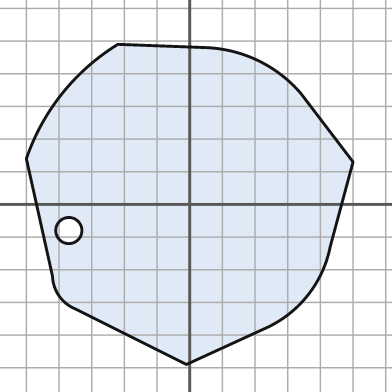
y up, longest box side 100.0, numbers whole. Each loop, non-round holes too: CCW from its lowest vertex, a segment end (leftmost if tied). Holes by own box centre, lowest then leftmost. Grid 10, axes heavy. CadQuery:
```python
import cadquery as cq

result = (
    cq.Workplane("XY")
    .moveTo(-1.0, -49.0)
    .lineTo(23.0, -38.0)
    .threePointArc((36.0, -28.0), (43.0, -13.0))
    .lineTo(50.0, 13.0)
    .lineTo(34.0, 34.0)
    .threePointArc((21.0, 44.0), (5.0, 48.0))
    .lineTo(-22.0, 49.0)
    .threePointArc((-39.0, 34.0), (-50.0, 14.0))
    .lineTo(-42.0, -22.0)
    .threePointArc((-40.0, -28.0), (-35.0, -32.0))
    .close()
    .moveTo(-37.0, -8.0)
    .circle(4.0)
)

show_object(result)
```